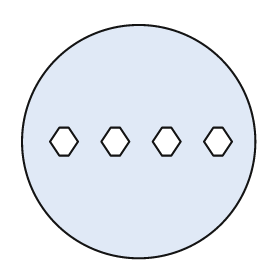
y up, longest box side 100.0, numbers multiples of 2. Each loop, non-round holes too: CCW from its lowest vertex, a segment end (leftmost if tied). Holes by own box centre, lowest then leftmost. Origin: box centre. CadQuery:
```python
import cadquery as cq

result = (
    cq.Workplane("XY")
    .moveTo(0.0, 0.0)
    .circle(50.0)
    .moveTo(-34.0, -6.0)
    .lineTo(-30.0, -6.0)
    .lineTo(-26.0, 0.0)
    .lineTo(-30.0, 6.0)
    .lineTo(-34.0, 6.0)
    .lineTo(-38.0, 0.0)
    .close()
    .moveTo(-12.0, -6.0)
    .lineTo(-8.0, -6.0)
    .lineTo(-4.0, 0.0)
    .lineTo(-8.0, 6.0)
    .lineTo(-12.0, 6.0)
    .lineTo(-16.0, 0.0)
    .close()
    .moveTo(10.0, -6.0)
    .lineTo(14.0, -6.0)
    .lineTo(18.0, 0.0)
    .lineTo(14.0, 6.0)
    .lineTo(10.0, 6.0)
    .lineTo(6.0, 0.0)
    .close()
    .moveTo(32.0, -6.0)
    .lineTo(36.0, -6.0)
    .lineTo(40.0, 0.0)
    .lineTo(36.0, 6.0)
    .lineTo(32.0, 6.0)
    .lineTo(28.0, 0.0)
    .close()
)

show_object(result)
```